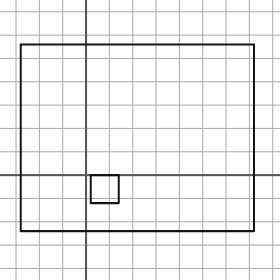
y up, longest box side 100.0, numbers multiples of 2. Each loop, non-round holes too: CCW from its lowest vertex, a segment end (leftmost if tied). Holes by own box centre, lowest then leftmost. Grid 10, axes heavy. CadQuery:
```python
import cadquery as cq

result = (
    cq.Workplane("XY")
    .moveTo(-28.0, -24.0)
    .lineTo(72.0, -24.0)
    .lineTo(72.0, 56.0)
    .lineTo(-28.0, 56.0)
    .close()
    .moveTo(2.0, -12.0)
    .lineTo(14.0, -12.0)
    .lineTo(14.0, 0.0)
    .lineTo(2.0, 0.0)
    .close()
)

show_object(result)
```